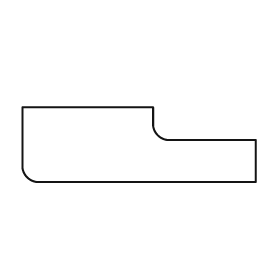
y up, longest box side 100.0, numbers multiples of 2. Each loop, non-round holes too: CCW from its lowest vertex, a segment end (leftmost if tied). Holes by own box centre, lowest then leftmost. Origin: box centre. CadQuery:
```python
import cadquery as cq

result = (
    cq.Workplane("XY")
    .moveTo(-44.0, -16.0)
    .lineTo(50.0, -16.0)
    .lineTo(50.0, 2.0)
    .lineTo(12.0, 2.0)
    .threePointArc((8.0, 4.0), (6.0, 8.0))
    .lineTo(6.0, 16.0)
    .lineTo(-50.0, 16.0)
    .lineTo(-50.0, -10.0)
    .threePointArc((-48.0, -14.0), (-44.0, -16.0))
    .close()
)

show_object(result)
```